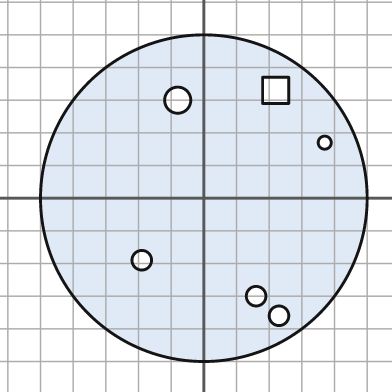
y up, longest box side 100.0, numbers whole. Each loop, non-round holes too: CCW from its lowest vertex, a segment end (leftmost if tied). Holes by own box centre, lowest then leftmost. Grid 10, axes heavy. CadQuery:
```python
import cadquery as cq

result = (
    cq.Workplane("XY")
    .moveTo(0.0, 0.0)
    .circle(50.0)
    .moveTo(23.0, -36.0)
    .circle(3.0)
    .moveTo(16.0, -30.0)
    .circle(3.0)
    .moveTo(-19.0, -19.0)
    .circle(3.0)
    .moveTo(37.0, 17.0)
    .circle(2.0)
    .moveTo(-8.0, 30.0)
    .circle(4.0)
    .moveTo(18.0, 29.0)
    .lineTo(26.0, 29.0)
    .lineTo(26.0, 37.0)
    .lineTo(18.0, 37.0)
    .close()
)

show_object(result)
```